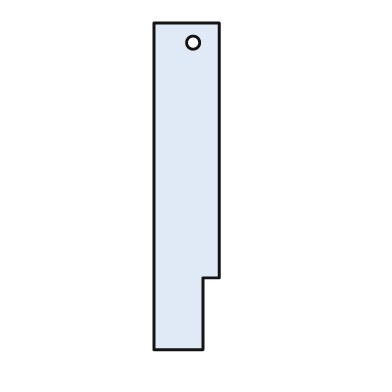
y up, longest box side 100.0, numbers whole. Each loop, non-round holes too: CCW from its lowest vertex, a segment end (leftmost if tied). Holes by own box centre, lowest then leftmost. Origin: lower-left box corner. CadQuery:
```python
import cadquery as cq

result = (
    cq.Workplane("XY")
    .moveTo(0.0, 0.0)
    .lineTo(15.0, 0.0)
    .lineTo(15.0, 22.0)
    .lineTo(20.0, 22.0)
    .lineTo(20.0, 100.0)
    .lineTo(0.0, 100.0)
    .close()
    .moveTo(12.0, 94.0)
    .circle(2.0)
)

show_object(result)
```